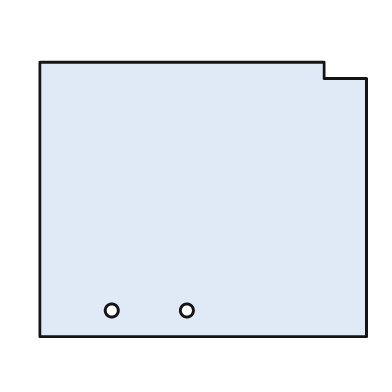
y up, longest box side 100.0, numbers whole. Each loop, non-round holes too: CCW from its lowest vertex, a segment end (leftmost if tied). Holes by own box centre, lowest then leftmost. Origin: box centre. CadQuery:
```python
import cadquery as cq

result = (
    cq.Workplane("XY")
    .moveTo(-50.0, -42.0)
    .lineTo(50.0, -42.0)
    .lineTo(50.0, 37.0)
    .lineTo(37.0, 37.0)
    .lineTo(37.0, 42.0)
    .lineTo(-50.0, 42.0)
    .close()
    .moveTo(-28.0, -34.0)
    .circle(2.0)
    .moveTo(-5.0, -34.0)
    .circle(2.0)
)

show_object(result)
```